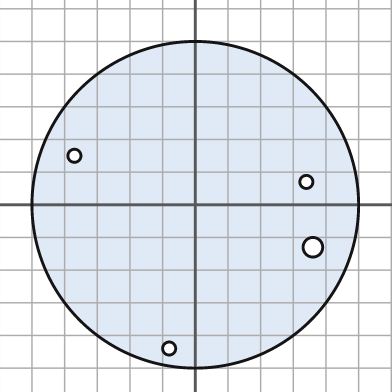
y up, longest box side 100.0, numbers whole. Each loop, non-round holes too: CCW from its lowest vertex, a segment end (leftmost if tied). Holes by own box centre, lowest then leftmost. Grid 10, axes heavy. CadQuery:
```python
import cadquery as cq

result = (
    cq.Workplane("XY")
    .moveTo(0.0, 0.0)
    .circle(50.0)
    .moveTo(-8.0, -44.0)
    .circle(2.0)
    .moveTo(36.0, -13.0)
    .circle(3.0)
    .moveTo(34.0, 7.0)
    .circle(2.0)
    .moveTo(-37.0, 15.0)
    .circle(2.0)
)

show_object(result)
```